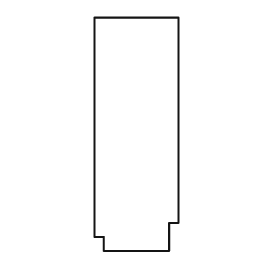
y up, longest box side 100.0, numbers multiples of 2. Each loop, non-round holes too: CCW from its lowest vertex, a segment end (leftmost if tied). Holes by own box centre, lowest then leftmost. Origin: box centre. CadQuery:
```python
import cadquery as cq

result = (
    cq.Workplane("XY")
    .moveTo(-14.0, -50.0)
    .lineTo(14.0, -50.0)
    .lineTo(14.0, -38.0)
    .lineTo(18.0, -38.0)
    .lineTo(18.0, 50.0)
    .lineTo(-18.0, 50.0)
    .lineTo(-18.0, -44.0)
    .lineTo(-14.0, -44.0)
    .close()
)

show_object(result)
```